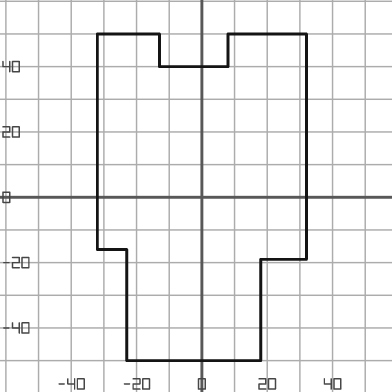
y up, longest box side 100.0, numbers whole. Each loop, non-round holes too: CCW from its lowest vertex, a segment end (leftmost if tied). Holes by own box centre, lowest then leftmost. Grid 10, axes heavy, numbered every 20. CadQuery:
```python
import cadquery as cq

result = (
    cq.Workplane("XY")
    .moveTo(-23.0, -50.0)
    .lineTo(18.0, -50.0)
    .lineTo(18.0, -19.0)
    .lineTo(32.0, -19.0)
    .lineTo(32.0, 50.0)
    .lineTo(8.0, 50.0)
    .lineTo(8.0, 40.0)
    .lineTo(-13.0, 40.0)
    .lineTo(-13.0, 50.0)
    .lineTo(-32.0, 50.0)
    .lineTo(-32.0, -16.0)
    .lineTo(-23.0, -16.0)
    .close()
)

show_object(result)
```